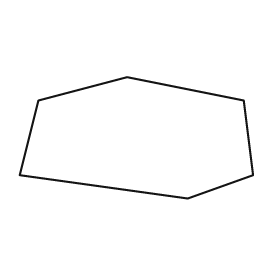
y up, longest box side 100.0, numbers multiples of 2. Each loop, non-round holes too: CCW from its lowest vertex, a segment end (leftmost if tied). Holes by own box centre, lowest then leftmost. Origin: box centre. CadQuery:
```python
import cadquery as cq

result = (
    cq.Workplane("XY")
    .moveTo(22.0, -26.0)
    .lineTo(50.0, -16.0)
    .lineTo(46.0, 16.0)
    .lineTo(-4.0, 26.0)
    .lineTo(-42.0, 16.0)
    .lineTo(-50.0, -16.0)
    .close()
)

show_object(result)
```